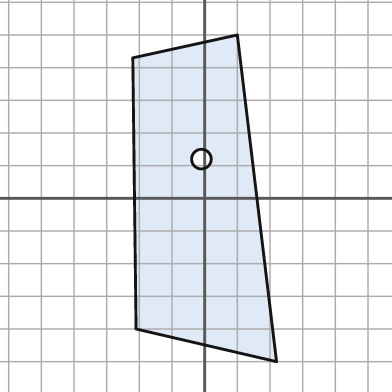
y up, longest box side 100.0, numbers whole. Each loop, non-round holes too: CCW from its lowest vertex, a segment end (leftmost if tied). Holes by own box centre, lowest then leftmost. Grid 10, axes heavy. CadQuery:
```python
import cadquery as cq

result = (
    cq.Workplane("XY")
    .moveTo(22.0, -50.0)
    .lineTo(10.0, 50.0)
    .lineTo(-22.0, 43.0)
    .lineTo(-21.0, -40.0)
    .close()
    .moveTo(-1.0, 12.0)
    .circle(3.0)
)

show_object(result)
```